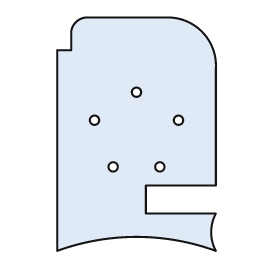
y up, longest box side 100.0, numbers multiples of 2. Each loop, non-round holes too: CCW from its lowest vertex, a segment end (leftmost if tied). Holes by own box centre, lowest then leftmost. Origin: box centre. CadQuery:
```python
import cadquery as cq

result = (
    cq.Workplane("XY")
    .moveTo(-34.0, -50.0)
    .threePointArc((0.0, -44.0), (34.0, -50.0))
    .threePointArc((32.0, -42.0), (34.0, -34.0))
    .lineTo(4.0, -34.0)
    .lineTo(4.0, -22.0)
    .lineTo(34.0, -22.0)
    .lineTo(34.0, 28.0)
    .threePointArc((28.0, 44.0), (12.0, 50.0))
    .lineTo(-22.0, 50.0)
    .threePointArc((-26.0, 48.0), (-28.0, 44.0))
    .lineTo(-28.0, 36.0)
    .lineTo(-34.0, 36.0)
    .close()
    .moveTo(-10.0, -14.0)
    .circle(2.0)
    .moveTo(10.0, -14.0)
    .circle(2.0)
    .moveTo(-18.0, 6.0)
    .circle(2.0)
    .moveTo(18.0, 6.0)
    .circle(2.0)
    .moveTo(0.0, 18.0)
    .circle(2.0)
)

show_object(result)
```